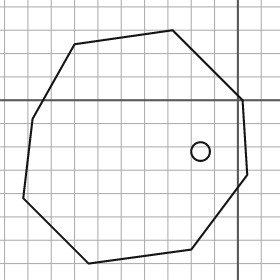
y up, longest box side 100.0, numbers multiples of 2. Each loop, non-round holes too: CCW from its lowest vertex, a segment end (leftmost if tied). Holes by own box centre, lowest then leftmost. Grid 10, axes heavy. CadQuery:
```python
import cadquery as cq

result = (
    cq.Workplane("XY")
    .moveTo(-64.0, -70.0)
    .lineTo(-20.0, -64.0)
    .lineTo(4.0, -32.0)
    .lineTo(2.0, 0.0)
    .lineTo(-28.0, 30.0)
    .lineTo(-70.0, 24.0)
    .lineTo(-88.0, -8.0)
    .lineTo(-92.0, -42.0)
    .close()
    .moveTo(-16.0, -22.0)
    .circle(4.0)
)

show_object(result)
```